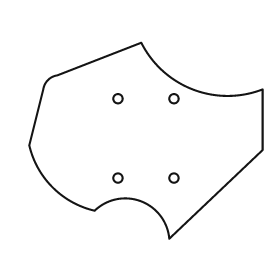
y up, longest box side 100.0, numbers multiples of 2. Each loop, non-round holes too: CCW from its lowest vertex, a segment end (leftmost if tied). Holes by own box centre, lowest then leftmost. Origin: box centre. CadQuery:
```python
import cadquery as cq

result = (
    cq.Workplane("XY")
    .moveTo(10.0, -42.0)
    .lineTo(50.0, -4.0)
    .lineTo(50.0, 22.0)
    .threePointArc((20.0, 22.0), (-2.0, 42.0))
    .lineTo(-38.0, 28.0)
    .threePointArc((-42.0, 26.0), (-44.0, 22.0))
    .lineTo(-50.0, -2.0)
    .threePointArc((-40.0, -20.0), (-22.0, -30.0))
    .threePointArc((-2.0, -26.0), (10.0, -42.0))
    .close()
    .moveTo(-12.0, -16.0)
    .circle(2.0)
    .moveTo(12.0, -16.0)
    .circle(2.0)
    .moveTo(-12.0, 18.0)
    .circle(2.0)
    .moveTo(12.0, 18.0)
    .circle(2.0)
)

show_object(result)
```